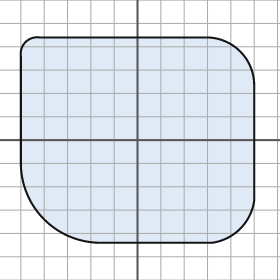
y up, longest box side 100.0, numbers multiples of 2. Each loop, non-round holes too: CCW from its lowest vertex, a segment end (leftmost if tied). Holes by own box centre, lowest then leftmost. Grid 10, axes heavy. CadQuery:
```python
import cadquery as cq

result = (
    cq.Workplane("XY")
    .moveTo(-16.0, -44.0)
    .lineTo(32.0, -44.0)
    .threePointArc((44.0, -38.0), (50.0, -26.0))
    .lineTo(50.0, 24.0)
    .threePointArc((44.0, 38.0), (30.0, 44.0))
    .lineTo(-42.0, 44.0)
    .threePointArc((-48.0, 42.0), (-50.0, 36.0))
    .lineTo(-50.0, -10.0)
    .threePointArc((-40.0, -34.0), (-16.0, -44.0))
    .close()
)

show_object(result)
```